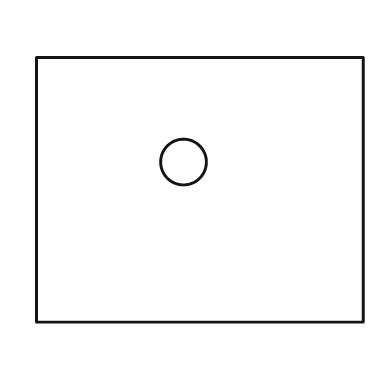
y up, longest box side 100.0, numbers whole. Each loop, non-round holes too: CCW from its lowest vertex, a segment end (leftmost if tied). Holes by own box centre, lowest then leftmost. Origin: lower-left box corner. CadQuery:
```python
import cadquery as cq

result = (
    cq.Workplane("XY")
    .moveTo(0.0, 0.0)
    .lineTo(100.0, 0.0)
    .lineTo(100.0, 81.0)
    .lineTo(0.0, 81.0)
    .close()
    .moveTo(45.0, 49.0)
    .circle(7.0)
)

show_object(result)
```